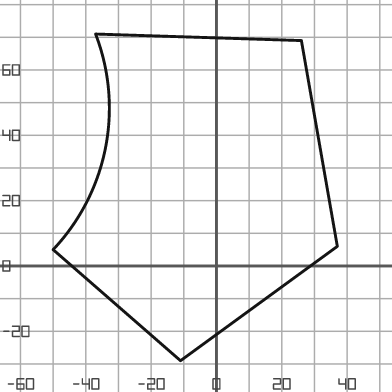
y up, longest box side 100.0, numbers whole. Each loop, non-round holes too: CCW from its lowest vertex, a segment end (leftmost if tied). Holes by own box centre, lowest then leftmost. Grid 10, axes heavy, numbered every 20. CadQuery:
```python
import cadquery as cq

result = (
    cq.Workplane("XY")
    .moveTo(-11.0, -29.0)
    .lineTo(37.0, 6.0)
    .lineTo(26.0, 69.0)
    .lineTo(-37.0, 71.0)
    .threePointArc((-34.0, 36.0), (-50.0, 5.0))
    .close()
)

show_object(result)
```